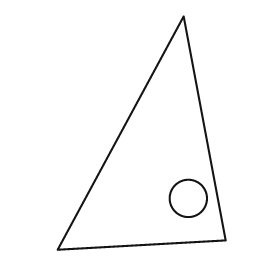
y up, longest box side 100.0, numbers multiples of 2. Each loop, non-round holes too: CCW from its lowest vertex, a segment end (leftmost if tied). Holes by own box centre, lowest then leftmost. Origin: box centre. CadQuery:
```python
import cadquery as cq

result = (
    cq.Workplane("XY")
    .moveTo(-36.0, -50.0)
    .lineTo(36.0, -46.0)
    .lineTo(18.0, 50.0)
    .close()
    .moveTo(20.0, -28.0)
    .circle(8.0)
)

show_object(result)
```